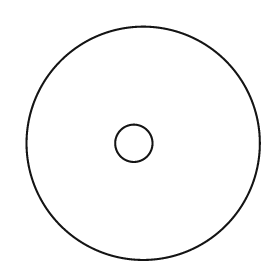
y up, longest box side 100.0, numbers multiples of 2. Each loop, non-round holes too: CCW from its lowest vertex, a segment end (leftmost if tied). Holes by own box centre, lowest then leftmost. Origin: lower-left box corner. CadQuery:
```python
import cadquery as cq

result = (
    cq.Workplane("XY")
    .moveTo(50.0, 50.0)
    .circle(50.0)
    .moveTo(46.0, 50.0)
    .circle(8.0)
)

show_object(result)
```